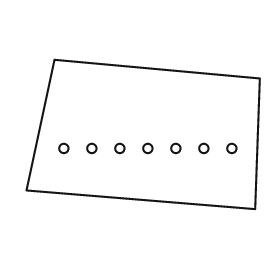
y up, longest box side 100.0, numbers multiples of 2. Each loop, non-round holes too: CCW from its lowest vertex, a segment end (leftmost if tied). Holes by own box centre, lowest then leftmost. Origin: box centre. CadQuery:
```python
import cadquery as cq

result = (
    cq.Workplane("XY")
    .moveTo(48.0, -32.0)
    .lineTo(50.0, 24.0)
    .lineTo(-38.0, 32.0)
    .lineTo(-50.0, -24.0)
    .close()
    .moveTo(-34.0, -6.0)
    .circle(2.0)
    .moveTo(-22.0, -6.0)
    .circle(2.0)
    .moveTo(-10.0, -6.0)
    .circle(2.0)
    .moveTo(2.0, -6.0)
    .circle(2.0)
    .moveTo(14.0, -6.0)
    .circle(2.0)
    .moveTo(26.0, -6.0)
    .circle(2.0)
    .moveTo(38.0, -6.0)
    .circle(2.0)
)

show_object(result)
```